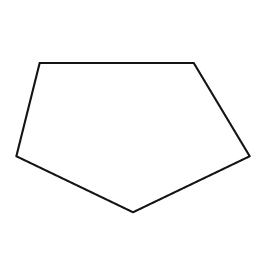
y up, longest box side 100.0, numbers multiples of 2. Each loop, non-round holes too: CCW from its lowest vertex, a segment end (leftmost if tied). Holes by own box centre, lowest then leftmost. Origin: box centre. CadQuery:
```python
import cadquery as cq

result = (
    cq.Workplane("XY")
    .moveTo(0.0, -32.0)
    .lineTo(50.0, -8.0)
    .lineTo(26.0, 32.0)
    .lineTo(-40.0, 32.0)
    .lineTo(-50.0, -8.0)
    .close()
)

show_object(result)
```